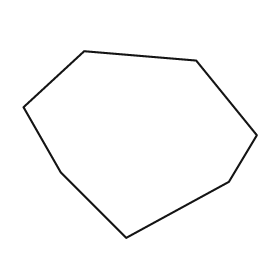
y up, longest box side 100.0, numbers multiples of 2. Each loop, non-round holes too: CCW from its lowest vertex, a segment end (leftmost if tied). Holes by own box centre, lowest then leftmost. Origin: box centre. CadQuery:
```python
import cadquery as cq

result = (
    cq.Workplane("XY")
    .moveTo(-6.0, -40.0)
    .lineTo(38.0, -16.0)
    .lineTo(50.0, 4.0)
    .lineTo(24.0, 36.0)
    .lineTo(-24.0, 40.0)
    .lineTo(-50.0, 16.0)
    .lineTo(-34.0, -12.0)
    .close()
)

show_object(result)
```